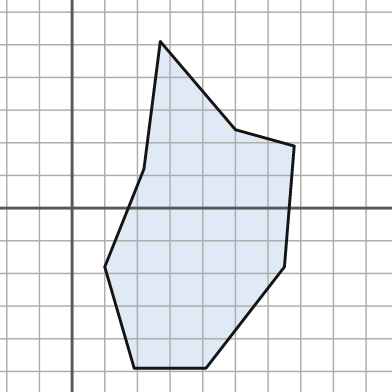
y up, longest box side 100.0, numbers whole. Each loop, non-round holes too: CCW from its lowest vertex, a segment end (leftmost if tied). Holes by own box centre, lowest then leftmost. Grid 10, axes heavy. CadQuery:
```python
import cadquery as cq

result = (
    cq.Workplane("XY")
    .moveTo(19.0, -49.0)
    .lineTo(41.0, -49.0)
    .lineTo(65.0, -18.0)
    .lineTo(68.0, 19.0)
    .lineTo(50.0, 24.0)
    .lineTo(27.0, 51.0)
    .lineTo(22.0, 12.0)
    .lineTo(10.0, -18.0)
    .close()
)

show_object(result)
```